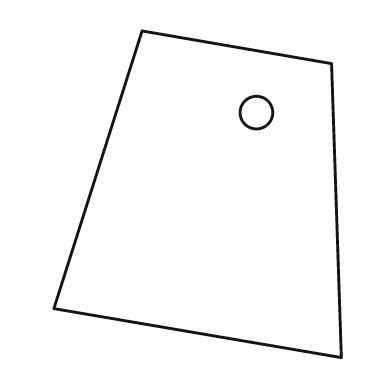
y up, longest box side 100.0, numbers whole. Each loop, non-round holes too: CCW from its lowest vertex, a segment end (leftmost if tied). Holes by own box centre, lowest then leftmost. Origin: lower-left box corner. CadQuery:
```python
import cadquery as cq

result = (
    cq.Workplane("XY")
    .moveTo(88.0, 0.0)
    .lineTo(85.0, 90.0)
    .lineTo(27.0, 100.0)
    .lineTo(0.0, 15.0)
    .close()
    .moveTo(62.0, 75.0)
    .circle(5.0)
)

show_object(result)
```